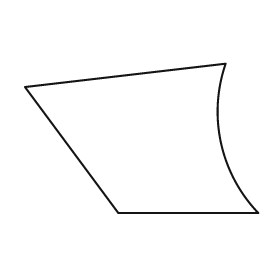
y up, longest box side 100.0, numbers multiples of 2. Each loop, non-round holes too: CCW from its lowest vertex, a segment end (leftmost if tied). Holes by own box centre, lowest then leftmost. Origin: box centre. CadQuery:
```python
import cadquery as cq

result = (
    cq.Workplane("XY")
    .moveTo(-10.0, -32.0)
    .lineTo(50.0, -32.0)
    .threePointArc((34.0, -2.0), (36.0, 32.0))
    .lineTo(-50.0, 22.0)
    .close()
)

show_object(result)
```